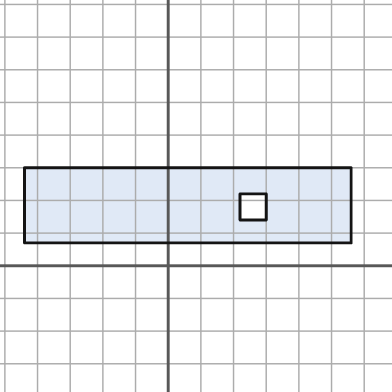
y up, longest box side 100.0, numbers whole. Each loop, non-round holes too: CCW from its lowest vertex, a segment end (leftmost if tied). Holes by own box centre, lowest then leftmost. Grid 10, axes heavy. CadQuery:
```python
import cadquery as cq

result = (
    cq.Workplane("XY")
    .moveTo(-44.0, 7.0)
    .lineTo(56.0, 7.0)
    .lineTo(56.0, 30.0)
    .lineTo(-44.0, 30.0)
    .close()
    .moveTo(22.0, 14.0)
    .lineTo(30.0, 14.0)
    .lineTo(30.0, 22.0)
    .lineTo(22.0, 22.0)
    .close()
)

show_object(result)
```